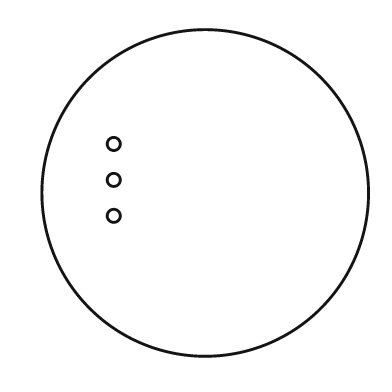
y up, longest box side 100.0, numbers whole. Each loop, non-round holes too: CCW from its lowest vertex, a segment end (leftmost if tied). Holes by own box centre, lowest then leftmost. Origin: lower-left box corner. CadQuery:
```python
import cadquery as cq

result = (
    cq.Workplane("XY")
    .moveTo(50.0, 50.0)
    .circle(50.0)
    .moveTo(22.0, 43.0)
    .circle(2.0)
    .moveTo(22.0, 54.0)
    .circle(2.0)
    .moveTo(22.0, 65.0)
    .circle(2.0)
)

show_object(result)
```